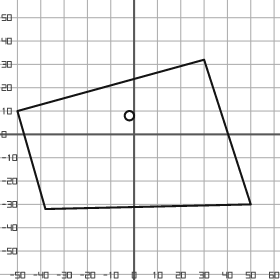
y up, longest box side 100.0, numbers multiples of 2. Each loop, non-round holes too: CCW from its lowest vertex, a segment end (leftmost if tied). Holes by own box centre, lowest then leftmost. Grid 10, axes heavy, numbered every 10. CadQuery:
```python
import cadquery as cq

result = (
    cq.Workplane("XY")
    .moveTo(-38.0, -32.0)
    .lineTo(50.0, -30.0)
    .lineTo(30.0, 32.0)
    .lineTo(-50.0, 10.0)
    .close()
    .moveTo(-2.0, 8.0)
    .circle(2.0)
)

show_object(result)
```